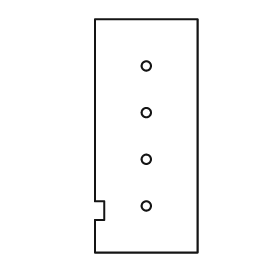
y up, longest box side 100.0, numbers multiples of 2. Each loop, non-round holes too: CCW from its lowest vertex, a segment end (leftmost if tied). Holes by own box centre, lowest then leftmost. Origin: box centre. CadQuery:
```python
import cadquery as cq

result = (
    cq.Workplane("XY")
    .moveTo(-22.0, -50.0)
    .lineTo(22.0, -50.0)
    .lineTo(22.0, 50.0)
    .lineTo(-22.0, 50.0)
    .lineTo(-22.0, -28.0)
    .lineTo(-18.0, -28.0)
    .lineTo(-18.0, -36.0)
    .lineTo(-22.0, -36.0)
    .close()
    .moveTo(0.0, -30.0)
    .circle(2.0)
    .moveTo(0.0, -10.0)
    .circle(2.0)
    .moveTo(0.0, 10.0)
    .circle(2.0)
    .moveTo(0.0, 30.0)
    .circle(2.0)
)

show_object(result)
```